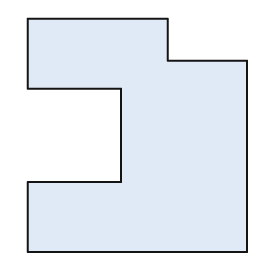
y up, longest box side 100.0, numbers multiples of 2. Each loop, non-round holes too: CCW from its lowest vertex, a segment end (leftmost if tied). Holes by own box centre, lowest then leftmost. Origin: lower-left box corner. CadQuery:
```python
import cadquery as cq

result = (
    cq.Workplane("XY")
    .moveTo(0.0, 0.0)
    .lineTo(94.0, 0.0)
    .lineTo(94.0, 82.0)
    .lineTo(60.0, 82.0)
    .lineTo(60.0, 100.0)
    .lineTo(0.0, 100.0)
    .lineTo(0.0, 70.0)
    .lineTo(40.0, 70.0)
    .lineTo(40.0, 30.0)
    .lineTo(0.0, 30.0)
    .close()
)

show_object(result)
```